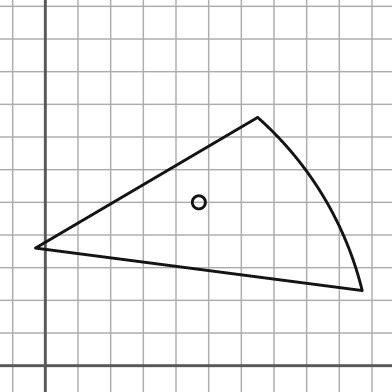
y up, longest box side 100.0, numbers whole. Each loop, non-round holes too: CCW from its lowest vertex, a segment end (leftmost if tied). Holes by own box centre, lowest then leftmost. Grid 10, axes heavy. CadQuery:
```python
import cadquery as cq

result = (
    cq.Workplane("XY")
    .moveTo(97.0, 23.0)
    .threePointArc((85.0, 52.0), (65.0, 76.0))
    .lineTo(-3.0, 36.0)
    .close()
    .moveTo(47.0, 50.0)
    .circle(2.0)
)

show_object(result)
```